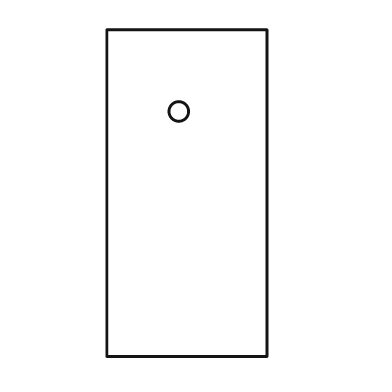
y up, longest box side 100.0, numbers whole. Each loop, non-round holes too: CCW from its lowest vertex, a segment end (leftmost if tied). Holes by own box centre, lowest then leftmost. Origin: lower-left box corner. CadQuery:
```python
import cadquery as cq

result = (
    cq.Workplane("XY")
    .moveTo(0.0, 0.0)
    .lineTo(49.0, 0.0)
    .lineTo(49.0, 100.0)
    .lineTo(0.0, 100.0)
    .close()
    .moveTo(22.0, 75.0)
    .circle(3.0)
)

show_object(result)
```